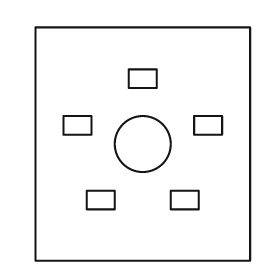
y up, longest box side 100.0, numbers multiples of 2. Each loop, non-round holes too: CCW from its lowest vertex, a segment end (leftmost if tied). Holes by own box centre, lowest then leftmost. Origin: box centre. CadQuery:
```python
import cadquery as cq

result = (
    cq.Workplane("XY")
    .moveTo(-46.0, -50.0)
    .lineTo(46.0, -50.0)
    .lineTo(46.0, 50.0)
    .lineTo(-46.0, 50.0)
    .close()
    .moveTo(-24.0, -28.0)
    .lineTo(-12.0, -28.0)
    .lineTo(-12.0, -20.0)
    .lineTo(-24.0, -20.0)
    .close()
    .moveTo(12.0, -28.0)
    .lineTo(24.0, -28.0)
    .lineTo(24.0, -20.0)
    .lineTo(12.0, -20.0)
    .close()
    .moveTo(0.0, 0.0)
    .circle(12.0)
    .moveTo(-34.0, 4.0)
    .lineTo(-22.0, 4.0)
    .lineTo(-22.0, 12.0)
    .lineTo(-34.0, 12.0)
    .close()
    .moveTo(22.0, 4.0)
    .lineTo(34.0, 4.0)
    .lineTo(34.0, 12.0)
    .lineTo(22.0, 12.0)
    .close()
    .moveTo(-6.0, 24.0)
    .lineTo(6.0, 24.0)
    .lineTo(6.0, 32.0)
    .lineTo(-6.0, 32.0)
    .close()
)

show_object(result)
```